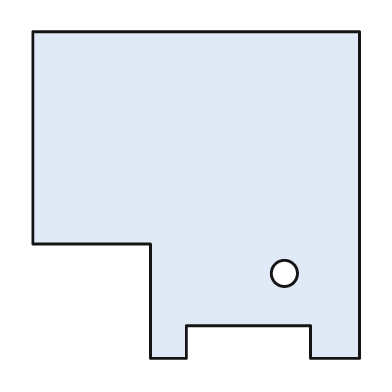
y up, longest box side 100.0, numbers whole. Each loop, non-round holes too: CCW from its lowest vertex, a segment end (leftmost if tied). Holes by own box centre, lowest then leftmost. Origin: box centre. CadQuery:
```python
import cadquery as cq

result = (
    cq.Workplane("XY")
    .moveTo(-14.0, -50.0)
    .lineTo(-3.0, -50.0)
    .lineTo(-3.0, -40.0)
    .lineTo(35.0, -40.0)
    .lineTo(35.0, -50.0)
    .lineTo(50.0, -50.0)
    .lineTo(50.0, 50.0)
    .lineTo(-50.0, 50.0)
    .lineTo(-50.0, -15.0)
    .lineTo(-14.0, -15.0)
    .close()
    .moveTo(27.0, -24.0)
    .circle(4.0)
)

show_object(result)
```